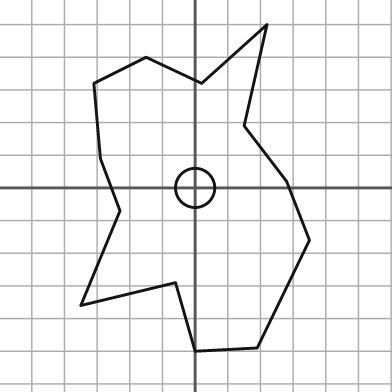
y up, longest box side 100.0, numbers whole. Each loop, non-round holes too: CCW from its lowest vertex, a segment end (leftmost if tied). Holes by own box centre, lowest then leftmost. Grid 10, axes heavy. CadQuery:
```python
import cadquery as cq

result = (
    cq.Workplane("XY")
    .moveTo(0.0, -50.0)
    .lineTo(19.0, -49.0)
    .lineTo(35.0, -16.0)
    .lineTo(28.0, 2.0)
    .lineTo(15.0, 19.0)
    .lineTo(22.0, 50.0)
    .lineTo(2.0, 32.0)
    .lineTo(-15.0, 40.0)
    .lineTo(-31.0, 32.0)
    .lineTo(-29.0, 9.0)
    .lineTo(-23.0, -7.0)
    .lineTo(-35.0, -36.0)
    .lineTo(-6.0, -29.0)
    .close()
    .moveTo(0.0, 0.0)
    .circle(6.0)
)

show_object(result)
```